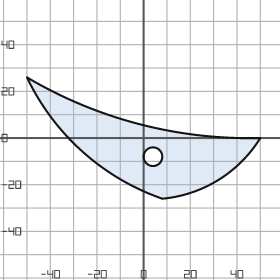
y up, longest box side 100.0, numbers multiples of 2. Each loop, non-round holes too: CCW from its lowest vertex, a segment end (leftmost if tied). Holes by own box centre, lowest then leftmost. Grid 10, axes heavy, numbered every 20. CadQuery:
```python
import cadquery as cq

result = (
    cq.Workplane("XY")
    .moveTo(8.0, -26.0)
    .threePointArc((32.0, -18.0), (50.0, 0.0))
    .threePointArc((-2.0, 6.0), (-50.0, 26.0))
    .threePointArc((-26.0, -6.0), (8.0, -26.0))
    .close()
    .moveTo(4.0, -8.0)
    .circle(4.0)
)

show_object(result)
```